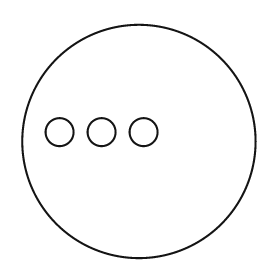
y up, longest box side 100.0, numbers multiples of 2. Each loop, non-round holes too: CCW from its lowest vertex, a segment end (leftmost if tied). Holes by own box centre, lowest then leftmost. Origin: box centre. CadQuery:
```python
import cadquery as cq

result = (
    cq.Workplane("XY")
    .moveTo(0.0, 0.0)
    .circle(50.0)
    .moveTo(-34.0, 4.0)
    .circle(6.0)
    .moveTo(-16.0, 4.0)
    .circle(6.0)
    .moveTo(2.0, 4.0)
    .circle(6.0)
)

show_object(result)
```